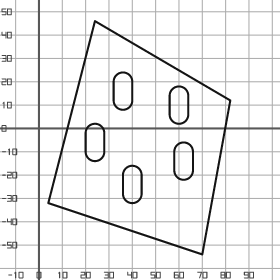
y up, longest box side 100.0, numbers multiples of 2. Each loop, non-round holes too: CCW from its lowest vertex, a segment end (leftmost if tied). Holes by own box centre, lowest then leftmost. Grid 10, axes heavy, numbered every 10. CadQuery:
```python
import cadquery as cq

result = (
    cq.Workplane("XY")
    .moveTo(70.0, -54.0)
    .lineTo(82.0, 12.0)
    .lineTo(24.0, 46.0)
    .lineTo(4.0, -32.0)
    .close()
    .moveTo(36.0, -28.0)
    .threePointArc((40.0, -32.0), (44.0, -28.0))
    .lineTo(44.0, -20.0)
    .threePointArc((40.0, -16.0), (36.0, -20.0))
    .close()
    .moveTo(58.0, -18.0)
    .threePointArc((62.0, -22.0), (66.0, -18.0))
    .lineTo(66.0, -10.0)
    .threePointArc((62.0, -6.0), (58.0, -10.0))
    .close()
    .moveTo(20.0, -10.0)
    .threePointArc((24.0, -14.0), (28.0, -10.0))
    .lineTo(28.0, -2.0)
    .threePointArc((24.0, 2.0), (20.0, -2.0))
    .close()
    .moveTo(56.0, 6.0)
    .threePointArc((60.0, 2.0), (64.0, 6.0))
    .lineTo(64.0, 14.0)
    .threePointArc((60.0, 18.0), (56.0, 14.0))
    .close()
    .moveTo(32.0, 12.0)
    .threePointArc((36.0, 8.0), (40.0, 12.0))
    .lineTo(40.0, 20.0)
    .threePointArc((36.0, 24.0), (32.0, 20.0))
    .close()
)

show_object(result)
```